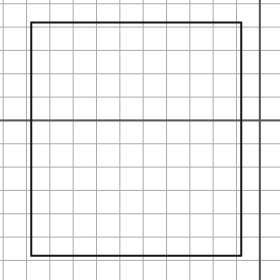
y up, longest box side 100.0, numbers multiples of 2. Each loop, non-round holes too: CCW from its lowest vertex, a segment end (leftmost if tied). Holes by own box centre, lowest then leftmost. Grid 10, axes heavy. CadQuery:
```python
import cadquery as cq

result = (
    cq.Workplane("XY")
    .moveTo(-98.0, -58.0)
    .lineTo(-8.0, -58.0)
    .lineTo(-8.0, 42.0)
    .lineTo(-98.0, 42.0)
    .close()
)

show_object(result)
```